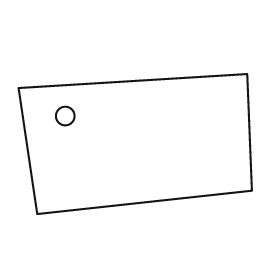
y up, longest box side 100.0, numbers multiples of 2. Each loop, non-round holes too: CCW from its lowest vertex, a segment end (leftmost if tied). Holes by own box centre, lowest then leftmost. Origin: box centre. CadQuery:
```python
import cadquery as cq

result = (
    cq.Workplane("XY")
    .moveTo(-42.0, -30.0)
    .lineTo(50.0, -20.0)
    .lineTo(48.0, 30.0)
    .lineTo(-50.0, 24.0)
    .close()
    .moveTo(-30.0, 12.0)
    .circle(4.0)
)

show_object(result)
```